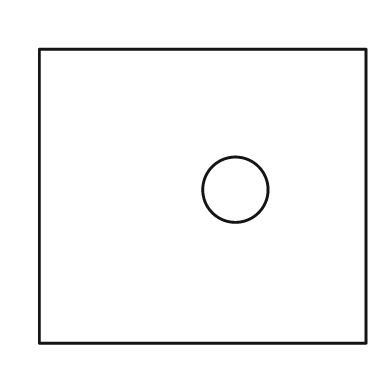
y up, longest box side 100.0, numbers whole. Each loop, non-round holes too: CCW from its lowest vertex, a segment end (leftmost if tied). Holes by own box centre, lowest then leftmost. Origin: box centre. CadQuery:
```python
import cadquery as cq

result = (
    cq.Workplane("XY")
    .moveTo(-50.0, -45.0)
    .lineTo(50.0, -45.0)
    .lineTo(50.0, 45.0)
    .lineTo(-50.0, 45.0)
    .close()
    .moveTo(10.0, 2.0)
    .circle(10.0)
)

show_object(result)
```